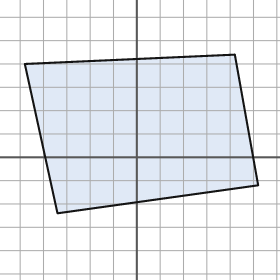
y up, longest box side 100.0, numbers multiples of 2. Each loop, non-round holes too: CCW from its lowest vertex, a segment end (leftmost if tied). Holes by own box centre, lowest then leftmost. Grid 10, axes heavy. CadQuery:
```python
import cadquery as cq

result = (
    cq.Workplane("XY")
    .moveTo(-34.0, -24.0)
    .lineTo(52.0, -12.0)
    .lineTo(42.0, 44.0)
    .lineTo(-48.0, 40.0)
    .close()
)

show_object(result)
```